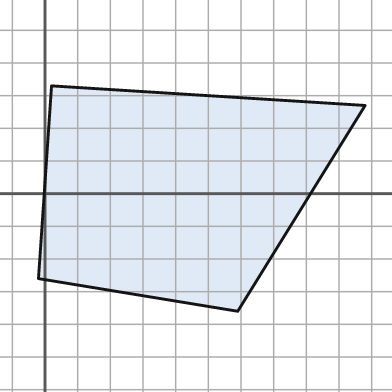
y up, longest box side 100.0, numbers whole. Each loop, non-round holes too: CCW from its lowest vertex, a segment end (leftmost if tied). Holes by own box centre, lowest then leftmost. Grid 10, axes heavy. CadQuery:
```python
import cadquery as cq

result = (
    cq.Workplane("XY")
    .moveTo(59.0, -36.0)
    .lineTo(98.0, 27.0)
    .lineTo(2.0, 33.0)
    .lineTo(-2.0, -26.0)
    .close()
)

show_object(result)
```